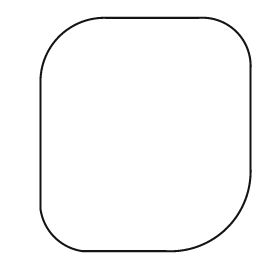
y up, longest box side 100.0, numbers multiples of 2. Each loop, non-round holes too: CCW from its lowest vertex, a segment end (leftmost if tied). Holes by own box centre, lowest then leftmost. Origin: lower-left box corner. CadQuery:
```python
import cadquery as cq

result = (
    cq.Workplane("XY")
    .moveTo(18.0, 0.0)
    .lineTo(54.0, 0.0)
    .threePointArc((80.0, 10.0), (90.0, 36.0))
    .lineTo(90.0, 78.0)
    .threePointArc((84.0, 94.0), (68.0, 100.0))
    .lineTo(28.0, 100.0)
    .threePointArc((8.0, 92.0), (0.0, 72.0))
    .lineTo(0.0, 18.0)
    .threePointArc((6.0, 6.0), (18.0, 0.0))
    .close()
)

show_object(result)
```